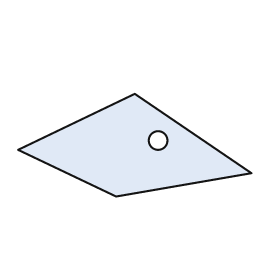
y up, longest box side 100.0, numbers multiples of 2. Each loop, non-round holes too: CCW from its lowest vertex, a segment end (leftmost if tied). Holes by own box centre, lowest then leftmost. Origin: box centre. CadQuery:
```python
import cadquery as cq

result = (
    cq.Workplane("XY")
    .moveTo(-8.0, -22.0)
    .lineTo(50.0, -12.0)
    .lineTo(0.0, 22.0)
    .lineTo(-50.0, -2.0)
    .close()
    .moveTo(10.0, 2.0)
    .circle(4.0)
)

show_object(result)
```